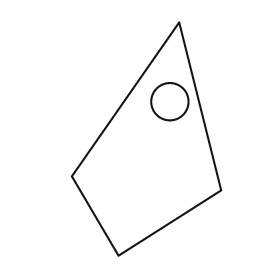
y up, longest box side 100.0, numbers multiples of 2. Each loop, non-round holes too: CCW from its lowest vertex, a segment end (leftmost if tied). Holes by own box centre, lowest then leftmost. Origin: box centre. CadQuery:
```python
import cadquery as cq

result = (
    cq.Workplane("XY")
    .moveTo(-12.0, -50.0)
    .lineTo(32.0, -22.0)
    .lineTo(14.0, 50.0)
    .lineTo(-32.0, -16.0)
    .close()
    .moveTo(10.0, 16.0)
    .circle(8.0)
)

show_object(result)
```